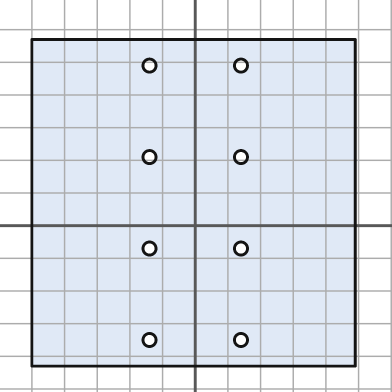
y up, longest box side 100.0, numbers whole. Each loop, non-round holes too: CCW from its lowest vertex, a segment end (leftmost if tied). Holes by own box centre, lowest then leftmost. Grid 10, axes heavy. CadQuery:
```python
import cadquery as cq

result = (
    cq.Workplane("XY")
    .moveTo(-50.0, -43.0)
    .lineTo(49.0, -43.0)
    .lineTo(49.0, 57.0)
    .lineTo(-50.0, 57.0)
    .close()
    .moveTo(-14.0, -35.0)
    .circle(2.0)
    .moveTo(14.0, -35.0)
    .circle(2.0)
    .moveTo(-14.0, -7.0)
    .circle(2.0)
    .moveTo(14.0, -7.0)
    .circle(2.0)
    .moveTo(-14.0, 21.0)
    .circle(2.0)
    .moveTo(14.0, 21.0)
    .circle(2.0)
    .moveTo(-14.0, 49.0)
    .circle(2.0)
    .moveTo(14.0, 49.0)
    .circle(2.0)
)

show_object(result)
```